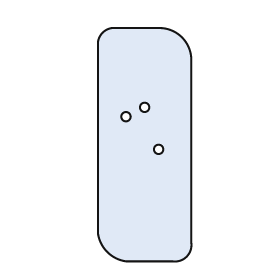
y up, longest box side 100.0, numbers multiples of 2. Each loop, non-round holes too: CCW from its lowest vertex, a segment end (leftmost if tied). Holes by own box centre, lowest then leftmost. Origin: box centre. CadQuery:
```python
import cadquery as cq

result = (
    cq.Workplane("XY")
    .moveTo(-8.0, -50.0)
    .lineTo(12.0, -50.0)
    .threePointArc((18.0, -48.0), (20.0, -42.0))
    .lineTo(20.0, 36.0)
    .threePointArc((16.0, 46.0), (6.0, 50.0))
    .lineTo(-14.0, 50.0)
    .threePointArc((-18.0, 48.0), (-20.0, 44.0))
    .lineTo(-20.0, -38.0)
    .threePointArc((-16.0, -46.0), (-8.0, -50.0))
    .close()
    .moveTo(6.0, -2.0)
    .circle(2.0)
    .moveTo(-8.0, 12.0)
    .circle(2.0)
    .moveTo(0.0, 16.0)
    .circle(2.0)
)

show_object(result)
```